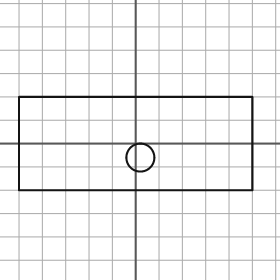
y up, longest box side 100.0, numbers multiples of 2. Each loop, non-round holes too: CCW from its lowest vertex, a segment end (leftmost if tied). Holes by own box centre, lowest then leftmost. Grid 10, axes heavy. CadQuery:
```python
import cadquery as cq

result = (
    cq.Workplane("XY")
    .moveTo(-50.0, -20.0)
    .lineTo(50.0, -20.0)
    .lineTo(50.0, 20.0)
    .lineTo(-50.0, 20.0)
    .close()
    .moveTo(2.0, -6.0)
    .circle(6.0)
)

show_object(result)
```